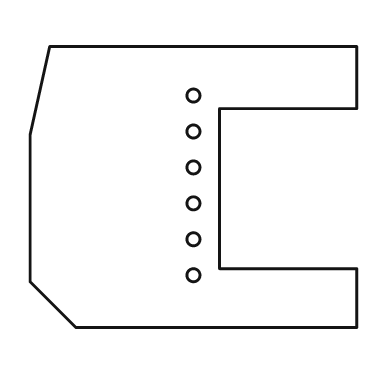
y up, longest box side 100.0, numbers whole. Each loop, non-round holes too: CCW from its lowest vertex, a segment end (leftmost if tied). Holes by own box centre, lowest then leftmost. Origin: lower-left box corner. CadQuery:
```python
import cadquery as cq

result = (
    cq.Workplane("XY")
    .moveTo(14.0, 0.0)
    .lineTo(100.0, 0.0)
    .lineTo(100.0, 18.0)
    .lineTo(58.0, 18.0)
    .lineTo(58.0, 67.0)
    .lineTo(100.0, 67.0)
    .lineTo(100.0, 86.0)
    .lineTo(6.0, 86.0)
    .lineTo(0.0, 59.0)
    .lineTo(0.0, 14.0)
    .close()
    .moveTo(50.0, 16.0)
    .circle(2.0)
    .moveTo(50.0, 27.0)
    .circle(2.0)
    .moveTo(50.0, 38.0)
    .circle(2.0)
    .moveTo(50.0, 49.0)
    .circle(2.0)
    .moveTo(50.0, 60.0)
    .circle(2.0)
    .moveTo(50.0, 71.0)
    .circle(2.0)
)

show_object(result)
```